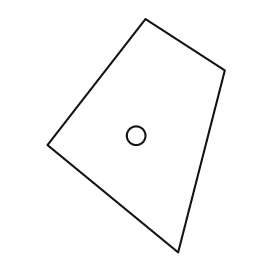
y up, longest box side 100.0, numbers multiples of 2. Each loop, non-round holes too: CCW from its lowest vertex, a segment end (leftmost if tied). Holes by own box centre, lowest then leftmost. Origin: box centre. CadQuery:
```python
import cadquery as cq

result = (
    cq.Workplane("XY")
    .moveTo(18.0, -50.0)
    .lineTo(38.0, 28.0)
    .lineTo(4.0, 50.0)
    .lineTo(-38.0, -4.0)
    .close()
    .moveTo(0.0, 0.0)
    .circle(4.0)
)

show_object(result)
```